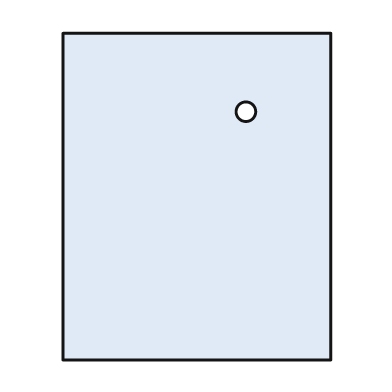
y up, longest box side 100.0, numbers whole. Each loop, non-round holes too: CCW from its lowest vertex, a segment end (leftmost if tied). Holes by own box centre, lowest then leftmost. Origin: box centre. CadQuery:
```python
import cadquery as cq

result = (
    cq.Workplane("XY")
    .moveTo(-41.0, -50.0)
    .lineTo(41.0, -50.0)
    .lineTo(41.0, 50.0)
    .lineTo(-41.0, 50.0)
    .close()
    .moveTo(15.0, 26.0)
    .circle(3.0)
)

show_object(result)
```